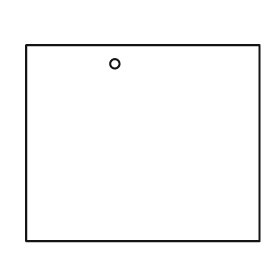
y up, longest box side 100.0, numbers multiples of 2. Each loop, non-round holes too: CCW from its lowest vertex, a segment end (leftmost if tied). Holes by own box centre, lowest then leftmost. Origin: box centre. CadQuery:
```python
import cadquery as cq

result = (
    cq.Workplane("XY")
    .moveTo(-50.0, -42.0)
    .lineTo(50.0, -42.0)
    .lineTo(50.0, 42.0)
    .lineTo(-50.0, 42.0)
    .close()
    .moveTo(-12.0, 34.0)
    .circle(2.0)
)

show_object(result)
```